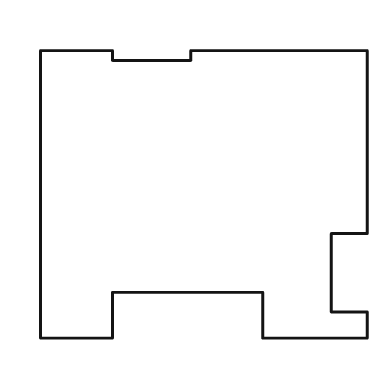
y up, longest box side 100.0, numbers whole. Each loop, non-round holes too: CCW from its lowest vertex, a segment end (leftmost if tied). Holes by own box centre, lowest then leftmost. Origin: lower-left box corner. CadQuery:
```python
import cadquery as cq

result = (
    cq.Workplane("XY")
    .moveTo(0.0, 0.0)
    .lineTo(22.0, 0.0)
    .lineTo(22.0, 14.0)
    .lineTo(68.0, 14.0)
    .lineTo(68.0, 0.0)
    .lineTo(100.0, 0.0)
    .lineTo(100.0, 8.0)
    .lineTo(89.0, 8.0)
    .lineTo(89.0, 32.0)
    .lineTo(100.0, 32.0)
    .lineTo(100.0, 88.0)
    .lineTo(46.0, 88.0)
    .lineTo(46.0, 85.0)
    .lineTo(22.0, 85.0)
    .lineTo(22.0, 88.0)
    .lineTo(0.0, 88.0)
    .close()
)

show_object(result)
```